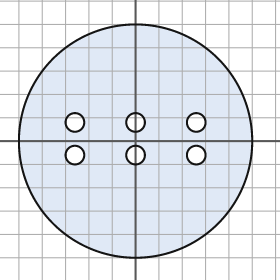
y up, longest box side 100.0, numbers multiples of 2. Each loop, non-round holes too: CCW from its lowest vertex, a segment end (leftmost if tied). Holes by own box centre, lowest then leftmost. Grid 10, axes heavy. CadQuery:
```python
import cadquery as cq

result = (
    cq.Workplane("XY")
    .moveTo(0.0, 0.0)
    .circle(50.0)
    .moveTo(-26.0, -6.0)
    .circle(4.0)
    .moveTo(0.0, -6.0)
    .circle(4.0)
    .moveTo(26.0, -6.0)
    .circle(4.0)
    .moveTo(-26.0, 8.0)
    .circle(4.0)
    .moveTo(0.0, 8.0)
    .circle(4.0)
    .moveTo(26.0, 8.0)
    .circle(4.0)
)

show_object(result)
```